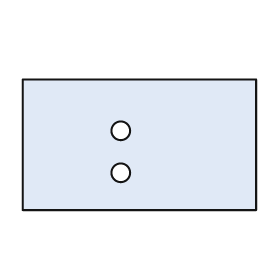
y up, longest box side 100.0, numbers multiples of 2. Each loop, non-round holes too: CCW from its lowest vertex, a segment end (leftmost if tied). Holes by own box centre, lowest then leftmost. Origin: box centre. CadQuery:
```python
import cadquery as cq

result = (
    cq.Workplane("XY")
    .moveTo(-50.0, -28.0)
    .lineTo(50.0, -28.0)
    .lineTo(50.0, 28.0)
    .lineTo(-50.0, 28.0)
    .close()
    .moveTo(-8.0, -12.0)
    .circle(4.0)
    .moveTo(-8.0, 6.0)
    .circle(4.0)
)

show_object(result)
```